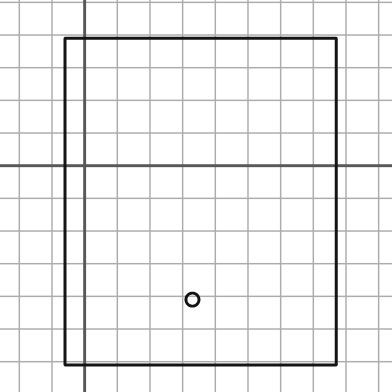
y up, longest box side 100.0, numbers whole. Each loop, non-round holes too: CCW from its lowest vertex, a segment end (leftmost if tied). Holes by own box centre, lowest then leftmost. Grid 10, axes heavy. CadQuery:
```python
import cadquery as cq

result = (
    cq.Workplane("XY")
    .moveTo(-6.0, -61.0)
    .lineTo(77.0, -61.0)
    .lineTo(77.0, 39.0)
    .lineTo(-6.0, 39.0)
    .close()
    .moveTo(33.0, -41.0)
    .circle(2.0)
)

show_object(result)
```